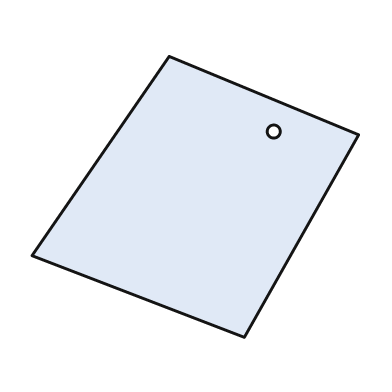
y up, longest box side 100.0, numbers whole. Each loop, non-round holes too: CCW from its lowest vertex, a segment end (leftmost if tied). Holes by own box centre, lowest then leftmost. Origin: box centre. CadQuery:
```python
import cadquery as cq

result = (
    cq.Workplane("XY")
    .moveTo(15.0, -43.0)
    .lineTo(50.0, 19.0)
    .lineTo(-8.0, 43.0)
    .lineTo(-50.0, -18.0)
    .close()
    .moveTo(24.0, 20.0)
    .circle(2.0)
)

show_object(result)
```